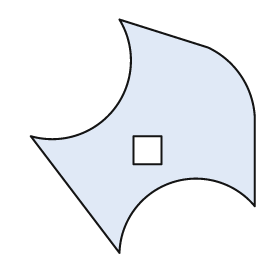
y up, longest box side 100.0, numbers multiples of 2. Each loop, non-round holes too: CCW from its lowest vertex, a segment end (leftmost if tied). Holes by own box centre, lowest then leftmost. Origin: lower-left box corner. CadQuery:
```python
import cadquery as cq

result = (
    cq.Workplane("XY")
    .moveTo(38.0, 0.0)
    .threePointArc((60.0, 30.0), (96.0, 20.0))
    .lineTo(96.0, 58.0)
    .threePointArc((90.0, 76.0), (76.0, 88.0))
    .lineTo(38.0, 100.0)
    .threePointArc((36.0, 62.0), (0.0, 50.0))
    .close()
    .moveTo(44.0, 38.0)
    .lineTo(56.0, 38.0)
    .lineTo(56.0, 50.0)
    .lineTo(44.0, 50.0)
    .close()
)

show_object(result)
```